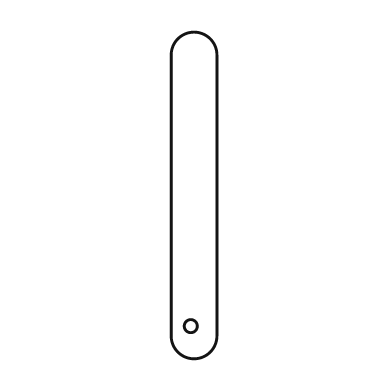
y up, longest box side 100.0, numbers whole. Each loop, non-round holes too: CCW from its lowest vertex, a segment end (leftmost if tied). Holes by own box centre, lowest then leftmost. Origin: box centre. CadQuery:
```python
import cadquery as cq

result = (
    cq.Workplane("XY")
    .moveTo(-7.0, -43.0)
    .threePointArc((0.0, -50.0), (7.0, -43.0))
    .lineTo(7.0, 43.0)
    .threePointArc((0.0, 50.0), (-7.0, 43.0))
    .close()
    .moveTo(-1.0, -40.0)
    .circle(2.0)
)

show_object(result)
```